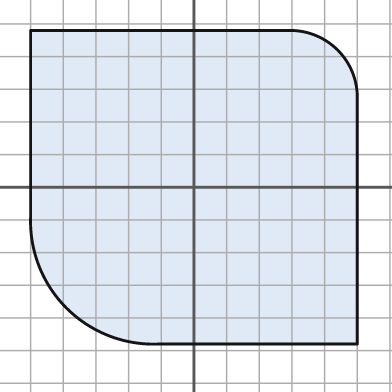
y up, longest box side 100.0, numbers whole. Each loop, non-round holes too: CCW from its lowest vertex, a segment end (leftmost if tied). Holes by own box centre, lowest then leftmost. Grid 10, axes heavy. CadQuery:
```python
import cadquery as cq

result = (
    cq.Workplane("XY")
    .moveTo(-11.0, -48.0)
    .lineTo(50.0, -48.0)
    .lineTo(50.0, 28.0)
    .threePointArc((44.0, 42.0), (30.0, 48.0))
    .lineTo(-50.0, 48.0)
    .lineTo(-50.0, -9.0)
    .threePointArc((-39.0, -37.0), (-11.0, -48.0))
    .close()
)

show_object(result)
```